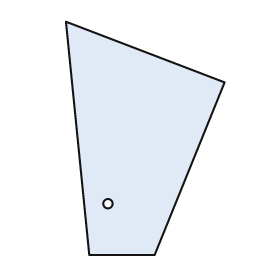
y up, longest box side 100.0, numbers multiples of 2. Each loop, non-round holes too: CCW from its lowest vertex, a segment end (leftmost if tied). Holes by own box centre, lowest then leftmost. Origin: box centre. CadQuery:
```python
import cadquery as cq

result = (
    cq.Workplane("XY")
    .moveTo(-24.0, -50.0)
    .lineTo(4.0, -50.0)
    .lineTo(34.0, 24.0)
    .lineTo(-34.0, 50.0)
    .close()
    .moveTo(-16.0, -28.0)
    .circle(2.0)
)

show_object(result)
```